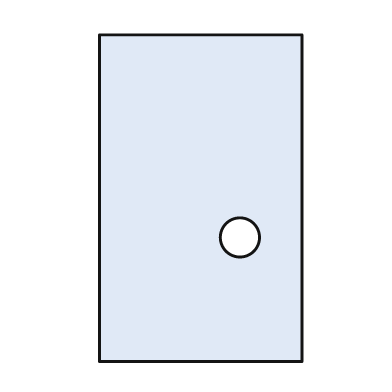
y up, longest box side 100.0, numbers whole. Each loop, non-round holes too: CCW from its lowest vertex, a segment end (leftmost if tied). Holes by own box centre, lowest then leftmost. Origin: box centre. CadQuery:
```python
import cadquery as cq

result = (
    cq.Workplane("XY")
    .moveTo(-31.0, -50.0)
    .lineTo(31.0, -50.0)
    .lineTo(31.0, 50.0)
    .lineTo(-31.0, 50.0)
    .close()
    .moveTo(12.0, -12.0)
    .circle(6.0)
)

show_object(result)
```